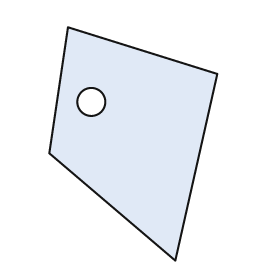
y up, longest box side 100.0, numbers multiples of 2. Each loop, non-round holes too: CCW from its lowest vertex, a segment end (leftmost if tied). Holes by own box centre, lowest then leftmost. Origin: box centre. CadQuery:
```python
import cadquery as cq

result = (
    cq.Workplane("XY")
    .moveTo(18.0, -50.0)
    .lineTo(36.0, 30.0)
    .lineTo(-28.0, 50.0)
    .lineTo(-36.0, -4.0)
    .close()
    .moveTo(-18.0, 18.0)
    .circle(6.0)
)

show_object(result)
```